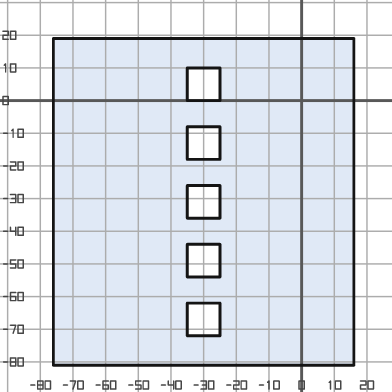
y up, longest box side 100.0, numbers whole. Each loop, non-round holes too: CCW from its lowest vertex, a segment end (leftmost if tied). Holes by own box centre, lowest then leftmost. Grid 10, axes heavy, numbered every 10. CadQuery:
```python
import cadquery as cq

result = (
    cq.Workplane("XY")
    .moveTo(-76.0, -81.0)
    .lineTo(16.0, -81.0)
    .lineTo(16.0, 19.0)
    .lineTo(-76.0, 19.0)
    .close()
    .moveTo(-35.0, -72.0)
    .lineTo(-25.0, -72.0)
    .lineTo(-25.0, -62.0)
    .lineTo(-35.0, -62.0)
    .close()
    .moveTo(-35.0, -54.0)
    .lineTo(-25.0, -54.0)
    .lineTo(-25.0, -44.0)
    .lineTo(-35.0, -44.0)
    .close()
    .moveTo(-35.0, -36.0)
    .lineTo(-25.0, -36.0)
    .lineTo(-25.0, -26.0)
    .lineTo(-35.0, -26.0)
    .close()
    .moveTo(-35.0, -18.0)
    .lineTo(-25.0, -18.0)
    .lineTo(-25.0, -8.0)
    .lineTo(-35.0, -8.0)
    .close()
    .moveTo(-35.0, 0.0)
    .lineTo(-25.0, 0.0)
    .lineTo(-25.0, 10.0)
    .lineTo(-35.0, 10.0)
    .close()
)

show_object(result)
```